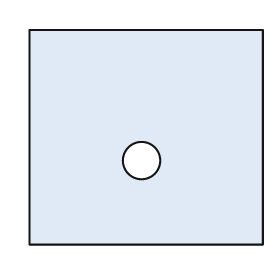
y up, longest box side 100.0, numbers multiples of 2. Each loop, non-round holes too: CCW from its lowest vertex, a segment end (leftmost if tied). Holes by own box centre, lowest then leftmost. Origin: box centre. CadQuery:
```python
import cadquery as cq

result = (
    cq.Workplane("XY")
    .moveTo(-50.0, -46.0)
    .lineTo(50.0, -46.0)
    .lineTo(50.0, 46.0)
    .lineTo(-50.0, 46.0)
    .close()
    .moveTo(-2.0, -10.0)
    .circle(8.0)
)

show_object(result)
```